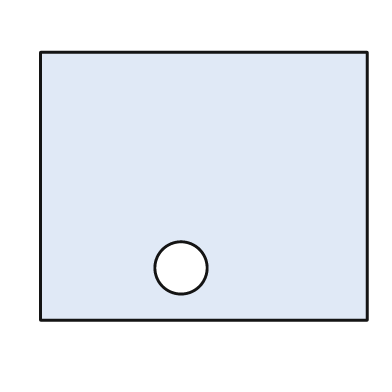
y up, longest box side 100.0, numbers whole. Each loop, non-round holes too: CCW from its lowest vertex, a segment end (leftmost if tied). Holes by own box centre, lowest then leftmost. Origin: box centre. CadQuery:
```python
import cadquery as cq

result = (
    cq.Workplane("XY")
    .moveTo(-50.0, -41.0)
    .lineTo(50.0, -41.0)
    .lineTo(50.0, 41.0)
    .lineTo(-50.0, 41.0)
    .close()
    .moveTo(-7.0, -25.0)
    .circle(8.0)
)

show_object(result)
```